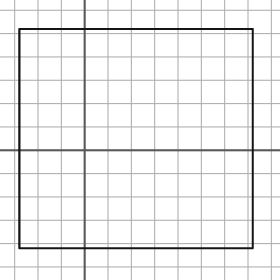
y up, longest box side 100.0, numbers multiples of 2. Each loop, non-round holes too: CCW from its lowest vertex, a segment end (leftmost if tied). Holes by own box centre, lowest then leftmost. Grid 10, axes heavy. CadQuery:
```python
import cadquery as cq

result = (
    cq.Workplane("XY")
    .moveTo(-28.0, -42.0)
    .lineTo(72.0, -42.0)
    .lineTo(72.0, 52.0)
    .lineTo(-28.0, 52.0)
    .close()
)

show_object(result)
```